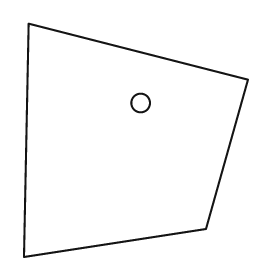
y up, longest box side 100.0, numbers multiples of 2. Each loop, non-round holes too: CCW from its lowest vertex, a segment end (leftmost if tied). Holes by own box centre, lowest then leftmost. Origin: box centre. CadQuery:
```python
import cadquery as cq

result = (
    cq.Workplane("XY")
    .moveTo(-48.0, -50.0)
    .lineTo(30.0, -38.0)
    .lineTo(48.0, 26.0)
    .lineTo(-46.0, 50.0)
    .close()
    .moveTo(2.0, 16.0)
    .circle(4.0)
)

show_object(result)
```